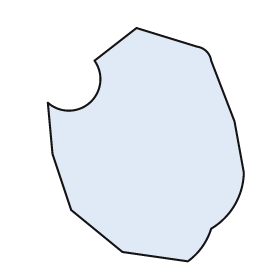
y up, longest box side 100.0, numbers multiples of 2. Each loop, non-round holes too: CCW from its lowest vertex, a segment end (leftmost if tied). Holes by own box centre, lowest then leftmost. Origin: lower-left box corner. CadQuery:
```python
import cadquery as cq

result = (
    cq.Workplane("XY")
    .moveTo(60.0, 0.0)
    .threePointArc((66.0, 6.0), (70.0, 14.0))
    .threePointArc((80.0, 24.0), (84.0, 38.0))
    .lineTo(80.0, 60.0)
    .lineTo(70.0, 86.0)
    .threePointArc((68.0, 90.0), (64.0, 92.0))
    .lineTo(38.0, 100.0)
    .lineTo(20.0, 86.0)
    .threePointArc((18.0, 68.0), (0.0, 68.0))
    .lineTo(2.0, 46.0)
    .lineTo(10.0, 22.0)
    .lineTo(32.0, 4.0)
    .close()
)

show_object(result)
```